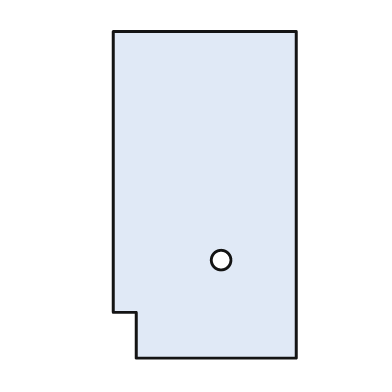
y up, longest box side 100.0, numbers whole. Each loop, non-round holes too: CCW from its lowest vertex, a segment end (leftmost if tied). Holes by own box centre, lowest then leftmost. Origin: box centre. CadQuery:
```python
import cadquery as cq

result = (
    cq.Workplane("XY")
    .moveTo(-21.0, -50.0)
    .lineTo(28.0, -50.0)
    .lineTo(28.0, 50.0)
    .lineTo(-28.0, 50.0)
    .lineTo(-28.0, -36.0)
    .lineTo(-21.0, -36.0)
    .close()
    .moveTo(5.0, -20.0)
    .circle(3.0)
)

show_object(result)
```